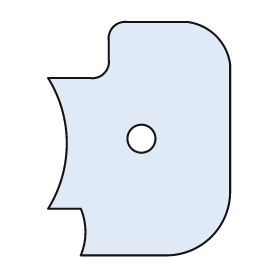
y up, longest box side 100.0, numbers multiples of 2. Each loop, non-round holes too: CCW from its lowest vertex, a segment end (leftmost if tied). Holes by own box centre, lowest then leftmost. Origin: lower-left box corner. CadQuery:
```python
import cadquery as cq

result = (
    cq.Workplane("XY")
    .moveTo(14.0, 0.0)
    .lineTo(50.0, 0.0)
    .threePointArc((70.0, 8.0), (78.0, 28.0))
    .lineTo(78.0, 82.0)
    .threePointArc((72.0, 94.0), (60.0, 100.0))
    .lineTo(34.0, 100.0)
    .threePointArc((28.0, 98.0), (26.0, 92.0))
    .lineTo(26.0, 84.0)
    .threePointArc((24.0, 78.0), (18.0, 76.0))
    .lineTo(0.0, 76.0)
    .threePointArc((8.0, 48.0), (0.0, 20.0))
    .lineTo(14.0, 20.0)
    .threePointArc((16.0, 10.0), (14.0, 0.0))
    .close()
    .moveTo(40.0, 50.0)
    .circle(6.0)
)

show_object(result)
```